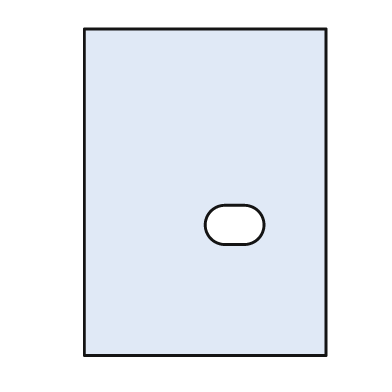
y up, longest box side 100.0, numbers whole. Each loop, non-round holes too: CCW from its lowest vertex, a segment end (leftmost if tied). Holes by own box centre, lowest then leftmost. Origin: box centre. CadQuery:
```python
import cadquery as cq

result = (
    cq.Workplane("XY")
    .moveTo(-37.0, -50.0)
    .lineTo(37.0, -50.0)
    .lineTo(37.0, 50.0)
    .lineTo(-37.0, 50.0)
    .close()
    .moveTo(6.0, -16.0)
    .lineTo(12.0, -16.0)
    .threePointArc((18.0, -10.0), (12.0, -4.0))
    .lineTo(6.0, -4.0)
    .threePointArc((0.0, -10.0), (6.0, -16.0))
    .close()
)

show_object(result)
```